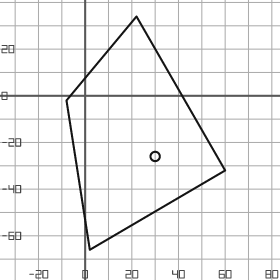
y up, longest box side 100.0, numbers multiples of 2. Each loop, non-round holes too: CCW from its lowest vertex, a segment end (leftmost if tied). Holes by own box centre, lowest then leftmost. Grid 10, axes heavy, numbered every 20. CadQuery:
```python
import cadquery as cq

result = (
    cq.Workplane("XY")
    .moveTo(2.0, -66.0)
    .lineTo(60.0, -32.0)
    .lineTo(22.0, 34.0)
    .lineTo(-8.0, -2.0)
    .close()
    .moveTo(30.0, -26.0)
    .circle(2.0)
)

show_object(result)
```